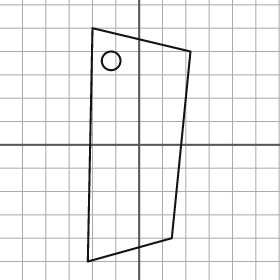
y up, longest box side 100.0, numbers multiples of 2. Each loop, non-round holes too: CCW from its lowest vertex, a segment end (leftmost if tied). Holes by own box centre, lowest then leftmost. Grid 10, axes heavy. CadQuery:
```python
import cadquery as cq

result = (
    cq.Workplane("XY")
    .moveTo(-22.0, -50.0)
    .lineTo(14.0, -40.0)
    .lineTo(22.0, 40.0)
    .lineTo(-20.0, 50.0)
    .close()
    .moveTo(-12.0, 36.0)
    .circle(4.0)
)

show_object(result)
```